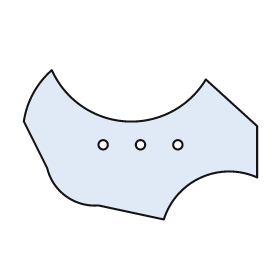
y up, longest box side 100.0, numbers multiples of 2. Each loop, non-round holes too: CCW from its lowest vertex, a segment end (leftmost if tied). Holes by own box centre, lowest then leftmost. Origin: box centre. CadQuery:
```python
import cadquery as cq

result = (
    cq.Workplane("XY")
    .moveTo(10.0, -32.0)
    .threePointArc((26.0, -14.0), (50.0, -14.0))
    .lineTo(50.0, 8.0)
    .lineTo(28.0, 28.0)
    .threePointArc((-6.0, 10.0), (-38.0, 32.0))
    .threePointArc((-46.0, 22.0), (-50.0, 10.0))
    .lineTo(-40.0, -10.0)
    .threePointArc((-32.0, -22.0), (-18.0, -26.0))
    .close()
    .moveTo(-16.0, 0.0)
    .circle(2.0)
    .moveTo(0.0, 0.0)
    .circle(2.0)
    .moveTo(16.0, 0.0)
    .circle(2.0)
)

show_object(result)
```